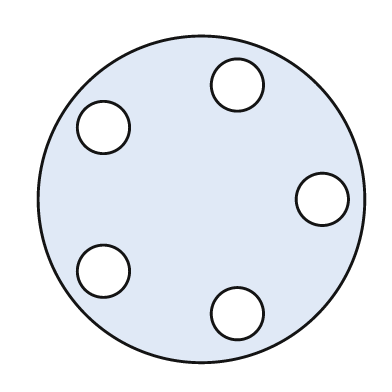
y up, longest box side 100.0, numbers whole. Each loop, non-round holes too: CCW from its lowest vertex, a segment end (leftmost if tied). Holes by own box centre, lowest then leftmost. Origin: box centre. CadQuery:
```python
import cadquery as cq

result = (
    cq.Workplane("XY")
    .moveTo(0.0, 0.0)
    .circle(50.0)
    .moveTo(11.0, -35.0)
    .circle(8.0)
    .moveTo(-30.0, -22.0)
    .circle(8.0)
    .moveTo(37.0, 0.0)
    .circle(8.0)
    .moveTo(-30.0, 22.0)
    .circle(8.0)
    .moveTo(11.0, 35.0)
    .circle(8.0)
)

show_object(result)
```